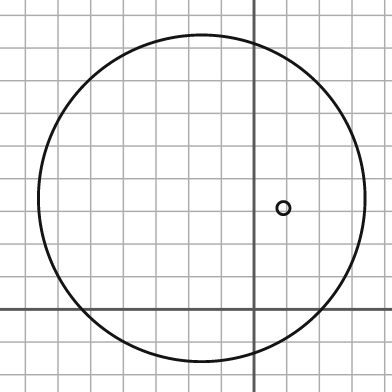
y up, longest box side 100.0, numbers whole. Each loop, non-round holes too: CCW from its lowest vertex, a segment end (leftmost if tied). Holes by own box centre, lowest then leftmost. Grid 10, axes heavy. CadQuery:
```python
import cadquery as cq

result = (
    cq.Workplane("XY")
    .moveTo(-16.0, 34.0)
    .circle(50.0)
    .moveTo(9.0, 31.0)
    .circle(2.0)
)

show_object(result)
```